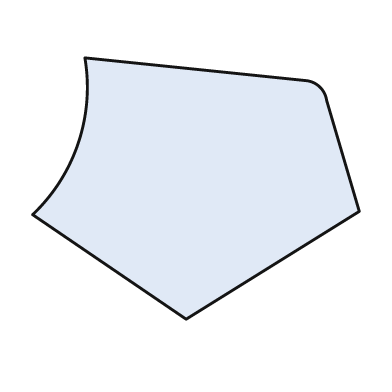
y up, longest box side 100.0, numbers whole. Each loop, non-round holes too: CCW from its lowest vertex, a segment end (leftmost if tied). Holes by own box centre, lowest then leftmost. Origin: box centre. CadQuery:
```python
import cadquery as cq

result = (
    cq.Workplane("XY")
    .moveTo(-3.0, -40.0)
    .lineTo(50.0, -7.0)
    .lineTo(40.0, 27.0)
    .threePointArc((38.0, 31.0), (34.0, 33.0))
    .lineTo(-34.0, 40.0)
    .threePointArc((-36.0, 14.0), (-50.0, -8.0))
    .close()
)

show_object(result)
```